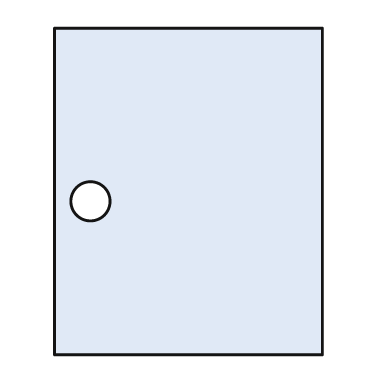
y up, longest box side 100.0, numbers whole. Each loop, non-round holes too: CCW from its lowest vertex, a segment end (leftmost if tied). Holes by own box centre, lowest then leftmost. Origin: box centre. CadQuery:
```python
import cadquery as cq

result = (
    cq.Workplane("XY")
    .moveTo(-41.0, -50.0)
    .lineTo(41.0, -50.0)
    .lineTo(41.0, 50.0)
    .lineTo(-41.0, 50.0)
    .close()
    .moveTo(-30.0, -3.0)
    .circle(6.0)
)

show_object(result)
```